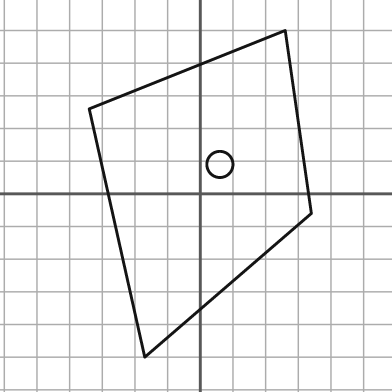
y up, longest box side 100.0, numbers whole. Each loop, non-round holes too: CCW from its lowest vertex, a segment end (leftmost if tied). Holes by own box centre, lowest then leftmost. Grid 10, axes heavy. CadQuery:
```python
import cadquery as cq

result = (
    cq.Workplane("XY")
    .moveTo(-17.0, -50.0)
    .lineTo(34.0, -6.0)
    .lineTo(26.0, 50.0)
    .lineTo(-34.0, 26.0)
    .close()
    .moveTo(6.0, 9.0)
    .circle(4.0)
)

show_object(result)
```